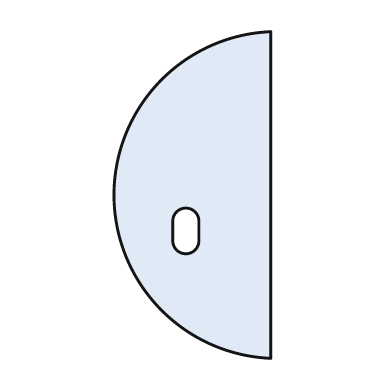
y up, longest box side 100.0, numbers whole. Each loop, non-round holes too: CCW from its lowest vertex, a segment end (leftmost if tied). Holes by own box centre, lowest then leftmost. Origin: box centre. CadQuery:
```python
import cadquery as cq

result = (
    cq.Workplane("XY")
    .moveTo(24.0, -50.0)
    .lineTo(24.0, 50.0)
    .threePointArc((-24.0, 0.0), (24.0, -50.0))
    .close()
    .moveTo(-6.0, -14.0)
    .threePointArc((-2.0, -18.0), (2.0, -14.0))
    .lineTo(2.0, -8.0)
    .threePointArc((-2.0, -4.0), (-6.0, -8.0))
    .close()
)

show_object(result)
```